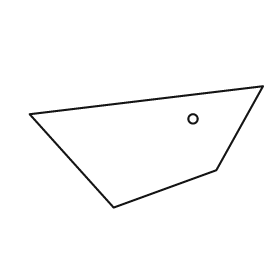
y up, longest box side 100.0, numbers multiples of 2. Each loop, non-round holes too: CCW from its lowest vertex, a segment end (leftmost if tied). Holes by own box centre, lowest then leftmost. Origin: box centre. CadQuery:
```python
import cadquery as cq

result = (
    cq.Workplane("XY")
    .moveTo(-14.0, -26.0)
    .lineTo(30.0, -10.0)
    .lineTo(50.0, 26.0)
    .lineTo(-50.0, 14.0)
    .close()
    .moveTo(20.0, 12.0)
    .circle(2.0)
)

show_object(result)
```